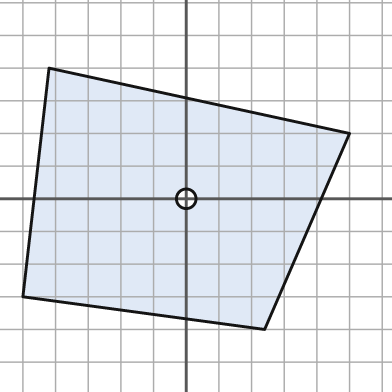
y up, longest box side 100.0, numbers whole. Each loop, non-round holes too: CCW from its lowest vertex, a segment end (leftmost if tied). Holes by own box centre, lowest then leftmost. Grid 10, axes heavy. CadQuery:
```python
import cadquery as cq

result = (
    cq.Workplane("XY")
    .moveTo(24.0, -40.0)
    .lineTo(50.0, 20.0)
    .lineTo(-42.0, 40.0)
    .lineTo(-50.0, -30.0)
    .close()
    .moveTo(0.0, 0.0)
    .circle(3.0)
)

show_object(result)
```